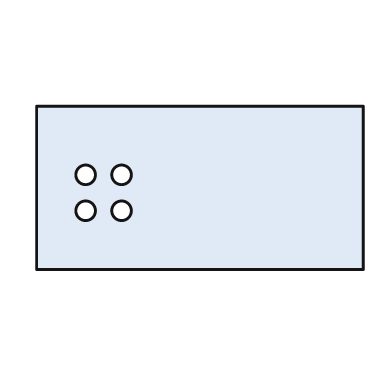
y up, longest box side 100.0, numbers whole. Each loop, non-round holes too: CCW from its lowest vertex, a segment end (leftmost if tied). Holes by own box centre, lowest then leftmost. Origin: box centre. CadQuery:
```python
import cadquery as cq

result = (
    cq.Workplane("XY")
    .moveTo(-50.0, -25.0)
    .lineTo(50.0, -25.0)
    .lineTo(50.0, 25.0)
    .lineTo(-50.0, 25.0)
    .close()
    .moveTo(-35.0, -7.0)
    .circle(3.0)
    .moveTo(-24.0, -7.0)
    .circle(3.0)
    .moveTo(-35.0, 4.0)
    .circle(3.0)
    .moveTo(-24.0, 4.0)
    .circle(3.0)
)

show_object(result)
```